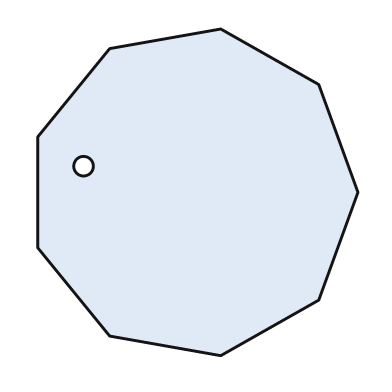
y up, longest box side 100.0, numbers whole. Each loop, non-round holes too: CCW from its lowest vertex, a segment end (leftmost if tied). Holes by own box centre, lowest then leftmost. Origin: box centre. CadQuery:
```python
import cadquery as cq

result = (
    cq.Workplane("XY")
    .moveTo(7.0, -50.0)
    .lineTo(37.0, -33.0)
    .lineTo(49.0, 0.0)
    .lineTo(37.0, 33.0)
    .lineTo(7.0, 50.0)
    .lineTo(-27.0, 44.0)
    .lineTo(-49.0, 17.0)
    .lineTo(-49.0, -17.0)
    .lineTo(-27.0, -44.0)
    .close()
    .moveTo(-35.0, 8.0)
    .circle(3.0)
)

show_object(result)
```